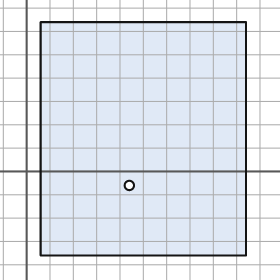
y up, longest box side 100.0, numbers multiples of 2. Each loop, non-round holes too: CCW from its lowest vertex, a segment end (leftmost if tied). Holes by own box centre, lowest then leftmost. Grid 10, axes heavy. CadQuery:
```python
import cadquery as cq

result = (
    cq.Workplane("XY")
    .moveTo(6.0, -36.0)
    .lineTo(94.0, -36.0)
    .lineTo(94.0, 64.0)
    .lineTo(6.0, 64.0)
    .close()
    .moveTo(44.0, -6.0)
    .circle(2.0)
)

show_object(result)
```